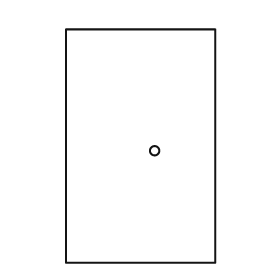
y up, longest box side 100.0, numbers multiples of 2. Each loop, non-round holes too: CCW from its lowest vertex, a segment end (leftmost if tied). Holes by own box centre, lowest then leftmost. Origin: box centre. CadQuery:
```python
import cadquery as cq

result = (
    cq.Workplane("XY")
    .moveTo(-32.0, -50.0)
    .lineTo(32.0, -50.0)
    .lineTo(32.0, 50.0)
    .lineTo(-32.0, 50.0)
    .close()
    .moveTo(6.0, -2.0)
    .circle(2.0)
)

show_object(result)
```